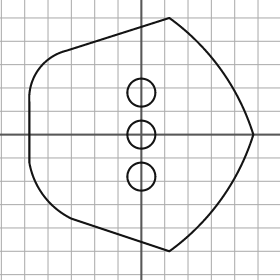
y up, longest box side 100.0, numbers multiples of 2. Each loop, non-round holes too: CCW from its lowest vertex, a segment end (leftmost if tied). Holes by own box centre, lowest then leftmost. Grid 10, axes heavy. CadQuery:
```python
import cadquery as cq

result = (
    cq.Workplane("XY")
    .moveTo(12.0, -50.0)
    .threePointArc((34.0, -28.0), (48.0, 0.0))
    .threePointArc((34.0, 28.0), (12.0, 50.0))
    .lineTo(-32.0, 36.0)
    .threePointArc((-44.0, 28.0), (-48.0, 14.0))
    .lineTo(-48.0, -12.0)
    .threePointArc((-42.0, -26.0), (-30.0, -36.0))
    .close()
    .moveTo(0.0, -18.0)
    .circle(6.0)
    .moveTo(0.0, 0.0)
    .circle(6.0)
    .moveTo(0.0, 18.0)
    .circle(6.0)
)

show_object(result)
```